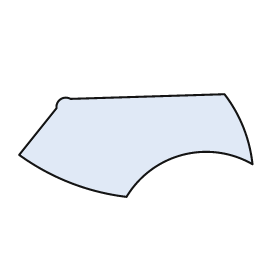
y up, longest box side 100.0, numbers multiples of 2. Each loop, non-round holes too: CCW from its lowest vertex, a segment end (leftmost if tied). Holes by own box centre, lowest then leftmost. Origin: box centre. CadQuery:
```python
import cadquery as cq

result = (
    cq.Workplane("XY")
    .moveTo(-4.0, -22.0)
    .threePointArc((20.0, -4.0), (50.0, -8.0))
    .threePointArc((46.0, 8.0), (38.0, 22.0))
    .lineTo(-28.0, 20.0)
    .threePointArc((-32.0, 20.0), (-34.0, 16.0))
    .lineTo(-50.0, -4.0)
    .threePointArc((-28.0, -16.0), (-4.0, -22.0))
    .close()
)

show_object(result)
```